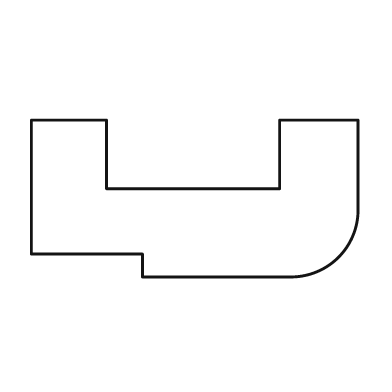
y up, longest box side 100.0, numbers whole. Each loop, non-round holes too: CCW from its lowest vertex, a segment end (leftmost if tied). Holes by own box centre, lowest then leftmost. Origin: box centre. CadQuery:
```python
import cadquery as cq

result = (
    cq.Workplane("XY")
    .moveTo(-16.0, -24.0)
    .lineTo(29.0, -24.0)
    .threePointArc((44.0, -18.0), (50.0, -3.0))
    .lineTo(50.0, 24.0)
    .lineTo(26.0, 24.0)
    .lineTo(26.0, 3.0)
    .lineTo(-27.0, 3.0)
    .lineTo(-27.0, 24.0)
    .lineTo(-50.0, 24.0)
    .lineTo(-50.0, -17.0)
    .lineTo(-16.0, -17.0)
    .close()
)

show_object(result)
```